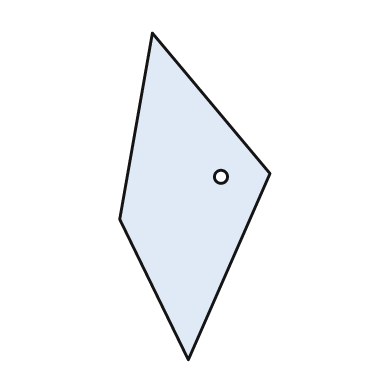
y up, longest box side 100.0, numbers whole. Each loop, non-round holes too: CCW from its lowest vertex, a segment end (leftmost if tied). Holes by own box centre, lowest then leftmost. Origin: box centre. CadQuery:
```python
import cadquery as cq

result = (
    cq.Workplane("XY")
    .moveTo(-2.0, -50.0)
    .lineTo(23.0, 7.0)
    .lineTo(-13.0, 50.0)
    .lineTo(-23.0, -7.0)
    .close()
    .moveTo(8.0, 6.0)
    .circle(2.0)
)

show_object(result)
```